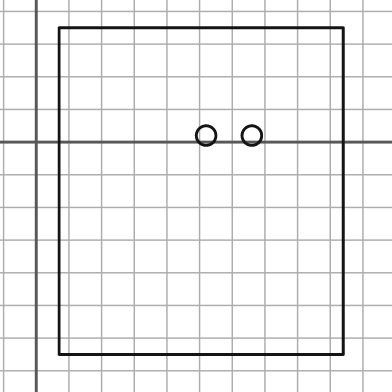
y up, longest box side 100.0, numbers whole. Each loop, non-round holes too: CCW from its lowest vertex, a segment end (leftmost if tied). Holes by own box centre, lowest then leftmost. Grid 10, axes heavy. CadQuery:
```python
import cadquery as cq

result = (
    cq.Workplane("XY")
    .moveTo(7.0, -65.0)
    .lineTo(94.0, -65.0)
    .lineTo(94.0, 35.0)
    .lineTo(7.0, 35.0)
    .close()
    .moveTo(52.0, 2.0)
    .circle(3.0)
    .moveTo(66.0, 2.0)
    .circle(3.0)
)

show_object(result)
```